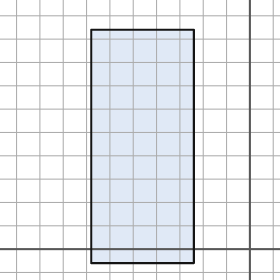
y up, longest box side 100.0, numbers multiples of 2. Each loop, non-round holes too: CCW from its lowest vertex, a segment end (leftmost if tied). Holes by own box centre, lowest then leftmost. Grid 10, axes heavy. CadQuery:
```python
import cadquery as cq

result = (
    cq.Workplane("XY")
    .moveTo(-68.0, -6.0)
    .lineTo(-24.0, -6.0)
    .lineTo(-24.0, 94.0)
    .lineTo(-68.0, 94.0)
    .close()
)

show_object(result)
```